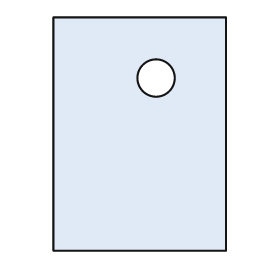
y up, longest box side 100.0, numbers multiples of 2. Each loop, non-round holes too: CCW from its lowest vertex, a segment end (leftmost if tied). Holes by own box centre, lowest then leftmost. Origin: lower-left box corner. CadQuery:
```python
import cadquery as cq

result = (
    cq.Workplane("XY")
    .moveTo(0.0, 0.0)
    .lineTo(74.0, 0.0)
    .lineTo(74.0, 100.0)
    .lineTo(0.0, 100.0)
    .close()
    .moveTo(44.0, 74.0)
    .circle(8.0)
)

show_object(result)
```